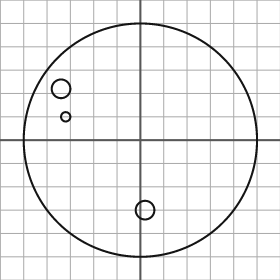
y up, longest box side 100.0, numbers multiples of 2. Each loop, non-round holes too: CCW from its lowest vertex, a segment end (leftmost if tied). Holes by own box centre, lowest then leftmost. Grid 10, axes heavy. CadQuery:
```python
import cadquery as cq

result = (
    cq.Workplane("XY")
    .moveTo(0.0, 0.0)
    .circle(50.0)
    .moveTo(2.0, -30.0)
    .circle(4.0)
    .moveTo(-32.0, 10.0)
    .circle(2.0)
    .moveTo(-34.0, 22.0)
    .circle(4.0)
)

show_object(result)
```